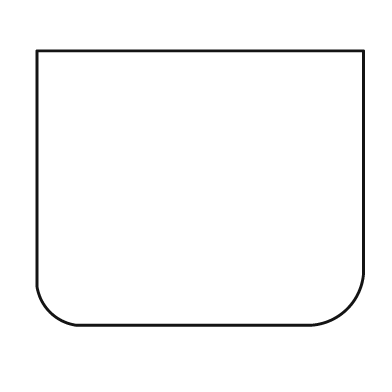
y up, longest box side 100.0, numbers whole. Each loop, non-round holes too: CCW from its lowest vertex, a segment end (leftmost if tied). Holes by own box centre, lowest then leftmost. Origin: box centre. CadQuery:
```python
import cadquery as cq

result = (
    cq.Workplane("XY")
    .moveTo(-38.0, -42.0)
    .lineTo(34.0, -42.0)
    .threePointArc((45.0, -37.0), (50.0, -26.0))
    .lineTo(50.0, 42.0)
    .lineTo(-50.0, 42.0)
    .lineTo(-50.0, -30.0)
    .threePointArc((-46.0, -38.0), (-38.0, -42.0))
    .close()
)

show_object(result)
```